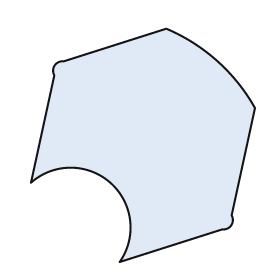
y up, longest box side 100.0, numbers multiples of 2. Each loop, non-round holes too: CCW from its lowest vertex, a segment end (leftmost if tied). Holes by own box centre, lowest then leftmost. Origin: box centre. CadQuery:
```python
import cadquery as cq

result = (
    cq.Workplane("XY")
    .moveTo(-10.0, -50.0)
    .lineTo(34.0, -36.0)
    .threePointArc((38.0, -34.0), (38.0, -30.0))
    .lineTo(48.0, 16.0)
    .threePointArc((32.0, 36.0), (10.0, 50.0))
    .lineTo(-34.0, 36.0)
    .threePointArc((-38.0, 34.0), (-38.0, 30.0))
    .lineTo(-48.0, -16.0)
    .threePointArc((-14.0, -16.0), (-10.0, -50.0))
    .close()
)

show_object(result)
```